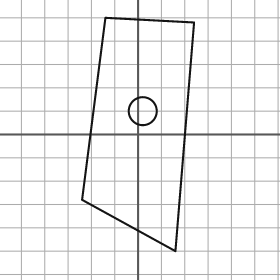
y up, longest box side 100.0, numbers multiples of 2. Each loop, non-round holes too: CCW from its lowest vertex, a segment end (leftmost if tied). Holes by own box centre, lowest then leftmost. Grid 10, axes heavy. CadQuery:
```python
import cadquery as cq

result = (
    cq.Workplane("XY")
    .moveTo(16.0, -50.0)
    .lineTo(24.0, 48.0)
    .lineTo(-14.0, 50.0)
    .lineTo(-24.0, -28.0)
    .close()
    .moveTo(2.0, 10.0)
    .circle(6.0)
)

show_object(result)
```